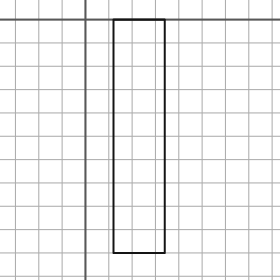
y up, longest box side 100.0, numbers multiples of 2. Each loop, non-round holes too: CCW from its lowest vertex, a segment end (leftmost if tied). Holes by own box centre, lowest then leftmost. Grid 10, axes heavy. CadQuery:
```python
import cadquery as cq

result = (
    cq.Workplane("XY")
    .moveTo(12.0, -100.0)
    .lineTo(34.0, -100.0)
    .lineTo(34.0, 0.0)
    .lineTo(12.0, 0.0)
    .close()
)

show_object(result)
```